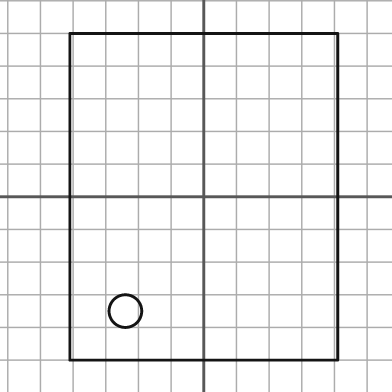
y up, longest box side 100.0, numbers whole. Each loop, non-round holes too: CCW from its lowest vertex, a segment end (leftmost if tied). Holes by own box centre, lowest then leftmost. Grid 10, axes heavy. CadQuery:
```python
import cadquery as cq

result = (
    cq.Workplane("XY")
    .moveTo(-41.0, -50.0)
    .lineTo(41.0, -50.0)
    .lineTo(41.0, 50.0)
    .lineTo(-41.0, 50.0)
    .close()
    .moveTo(-24.0, -35.0)
    .circle(5.0)
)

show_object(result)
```